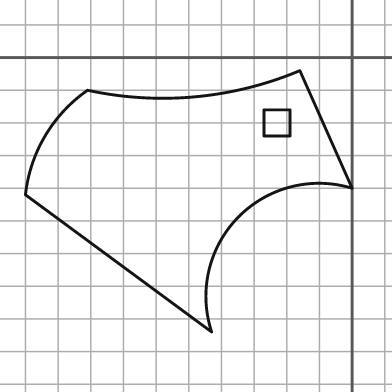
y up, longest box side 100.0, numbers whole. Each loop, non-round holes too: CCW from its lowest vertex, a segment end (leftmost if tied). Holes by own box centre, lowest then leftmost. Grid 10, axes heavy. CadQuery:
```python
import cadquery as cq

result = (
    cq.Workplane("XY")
    .moveTo(-43.0, -84.0)
    .threePointArc((-35.0, -49.0), (0.0, -40.0))
    .lineTo(-16.0, -4.0)
    .threePointArc((-48.0, -12.0), (-81.0, -10.0))
    .threePointArc((-94.0, -24.0), (-100.0, -42.0))
    .close()
    .moveTo(-27.0, -24.0)
    .lineTo(-19.0, -24.0)
    .lineTo(-19.0, -16.0)
    .lineTo(-27.0, -16.0)
    .close()
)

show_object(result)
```